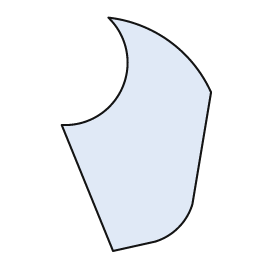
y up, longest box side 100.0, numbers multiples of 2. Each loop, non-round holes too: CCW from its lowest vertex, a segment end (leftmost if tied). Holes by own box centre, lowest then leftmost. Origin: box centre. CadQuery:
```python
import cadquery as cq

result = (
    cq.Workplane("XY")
    .moveTo(-10.0, -50.0)
    .lineTo(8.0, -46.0)
    .threePointArc((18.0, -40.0), (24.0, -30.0))
    .lineTo(32.0, 18.0)
    .threePointArc((14.0, 40.0), (-12.0, 50.0))
    .threePointArc((-6.0, 20.0), (-32.0, 4.0))
    .close()
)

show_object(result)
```